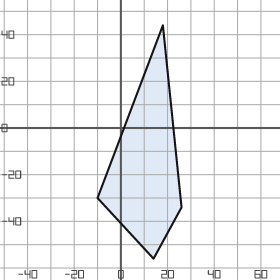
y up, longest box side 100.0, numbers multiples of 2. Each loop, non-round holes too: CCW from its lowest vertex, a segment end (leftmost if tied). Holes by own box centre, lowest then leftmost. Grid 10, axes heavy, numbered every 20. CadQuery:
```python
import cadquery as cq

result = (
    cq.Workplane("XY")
    .moveTo(14.0, -56.0)
    .lineTo(26.0, -34.0)
    .lineTo(18.0, 44.0)
    .lineTo(-10.0, -30.0)
    .close()
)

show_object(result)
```